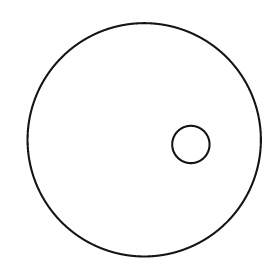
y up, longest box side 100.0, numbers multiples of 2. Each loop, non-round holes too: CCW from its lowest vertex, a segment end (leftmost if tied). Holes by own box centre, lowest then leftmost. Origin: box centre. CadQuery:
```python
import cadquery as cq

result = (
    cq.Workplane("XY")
    .moveTo(0.0, 0.0)
    .circle(50.0)
    .moveTo(20.0, -2.0)
    .circle(8.0)
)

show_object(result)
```